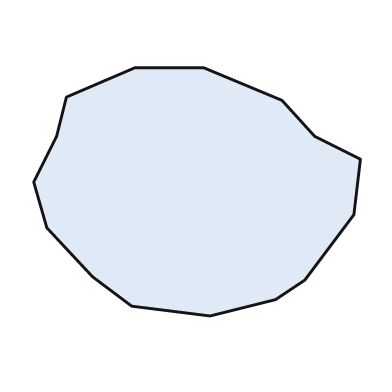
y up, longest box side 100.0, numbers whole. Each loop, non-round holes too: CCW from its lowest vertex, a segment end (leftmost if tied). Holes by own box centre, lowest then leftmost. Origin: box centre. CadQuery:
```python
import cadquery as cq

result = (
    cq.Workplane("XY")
    .moveTo(4.0, -38.0)
    .lineTo(24.0, -33.0)
    .lineTo(33.0, -27.0)
    .lineTo(48.0, -7.0)
    .lineTo(50.0, 10.0)
    .lineTo(36.0, 17.0)
    .lineTo(26.0, 28.0)
    .lineTo(2.0, 38.0)
    .lineTo(-19.0, 38.0)
    .lineTo(-40.0, 29.0)
    .lineTo(-43.0, 17.0)
    .lineTo(-50.0, 3.0)
    .lineTo(-46.0, -11.0)
    .lineTo(-32.0, -26.0)
    .lineTo(-20.0, -35.0)
    .close()
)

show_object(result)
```